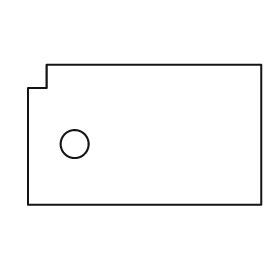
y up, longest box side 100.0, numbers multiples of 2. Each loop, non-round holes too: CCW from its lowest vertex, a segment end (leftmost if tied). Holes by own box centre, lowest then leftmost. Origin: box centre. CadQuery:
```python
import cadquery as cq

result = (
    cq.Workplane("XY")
    .moveTo(-50.0, -30.0)
    .lineTo(50.0, -30.0)
    .lineTo(50.0, 30.0)
    .lineTo(-42.0, 30.0)
    .lineTo(-42.0, 20.0)
    .lineTo(-50.0, 20.0)
    .close()
    .moveTo(-30.0, -4.0)
    .circle(6.0)
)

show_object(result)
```